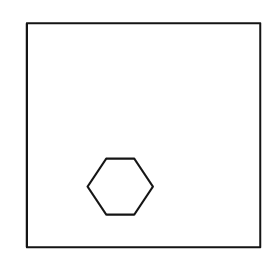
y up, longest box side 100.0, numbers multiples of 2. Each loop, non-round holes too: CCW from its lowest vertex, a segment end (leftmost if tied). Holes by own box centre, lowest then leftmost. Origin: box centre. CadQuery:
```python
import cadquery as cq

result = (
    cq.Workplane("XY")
    .moveTo(-50.0, -48.0)
    .lineTo(50.0, -48.0)
    .lineTo(50.0, 48.0)
    .lineTo(-50.0, 48.0)
    .close()
    .moveTo(-16.0, -34.0)
    .lineTo(-4.0, -34.0)
    .lineTo(4.0, -22.0)
    .lineTo(-4.0, -10.0)
    .lineTo(-16.0, -10.0)
    .lineTo(-24.0, -22.0)
    .close()
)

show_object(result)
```